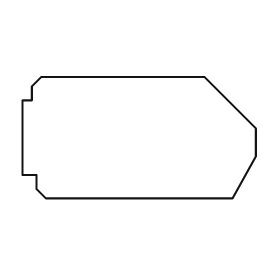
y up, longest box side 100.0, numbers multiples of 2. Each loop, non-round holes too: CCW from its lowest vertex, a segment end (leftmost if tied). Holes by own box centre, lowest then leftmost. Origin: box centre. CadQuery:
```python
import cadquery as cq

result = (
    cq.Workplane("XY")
    .moveTo(-40.0, -26.0)
    .lineTo(40.0, -26.0)
    .lineTo(50.0, -8.0)
    .lineTo(50.0, 4.0)
    .lineTo(28.0, 26.0)
    .lineTo(-42.0, 26.0)
    .lineTo(-46.0, 22.0)
    .lineTo(-46.0, 16.0)
    .lineTo(-50.0, 16.0)
    .lineTo(-50.0, -16.0)
    .lineTo(-44.0, -16.0)
    .lineTo(-44.0, -22.0)
    .close()
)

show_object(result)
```